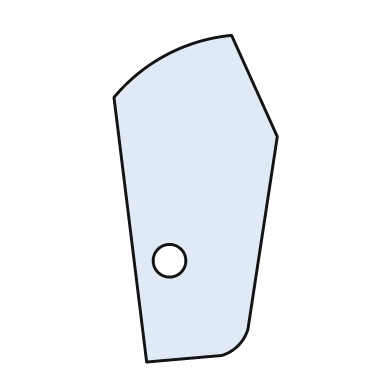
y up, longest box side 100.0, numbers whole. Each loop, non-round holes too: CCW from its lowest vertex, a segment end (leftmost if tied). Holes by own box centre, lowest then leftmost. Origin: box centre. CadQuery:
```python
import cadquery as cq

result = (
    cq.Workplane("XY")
    .moveTo(-15.0, -50.0)
    .lineTo(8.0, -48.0)
    .threePointArc((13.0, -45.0), (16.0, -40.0))
    .lineTo(25.0, 19.0)
    .lineTo(11.0, 50.0)
    .threePointArc((-9.0, 44.0), (-25.0, 31.0))
    .close()
    .moveTo(-8.0, -19.0)
    .circle(5.0)
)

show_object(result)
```